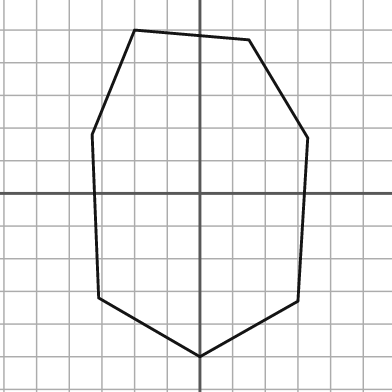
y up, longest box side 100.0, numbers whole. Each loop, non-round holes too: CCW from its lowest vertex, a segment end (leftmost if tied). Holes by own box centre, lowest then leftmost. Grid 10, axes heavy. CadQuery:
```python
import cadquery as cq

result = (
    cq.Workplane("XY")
    .moveTo(0.0, -50.0)
    .lineTo(30.0, -33.0)
    .lineTo(33.0, 17.0)
    .lineTo(15.0, 47.0)
    .lineTo(-20.0, 50.0)
    .lineTo(-33.0, 18.0)
    .lineTo(-31.0, -32.0)
    .close()
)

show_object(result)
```